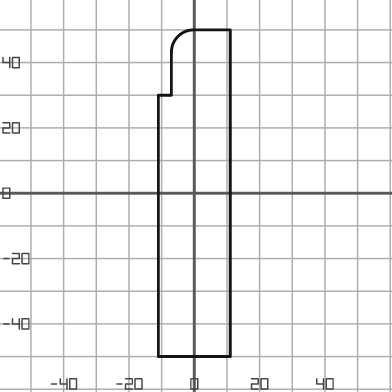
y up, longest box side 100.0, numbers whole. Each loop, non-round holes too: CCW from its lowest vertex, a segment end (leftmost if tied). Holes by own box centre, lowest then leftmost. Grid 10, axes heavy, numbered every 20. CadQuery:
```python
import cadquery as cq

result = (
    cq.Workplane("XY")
    .moveTo(-11.0, -50.0)
    .lineTo(11.0, -50.0)
    .lineTo(11.0, 50.0)
    .lineTo(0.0, 50.0)
    .threePointArc((-5.0, 48.0), (-7.0, 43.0))
    .lineTo(-7.0, 30.0)
    .lineTo(-11.0, 30.0)
    .close()
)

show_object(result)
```